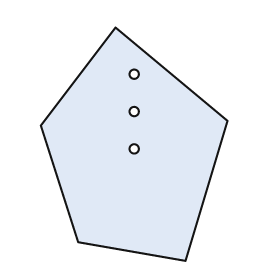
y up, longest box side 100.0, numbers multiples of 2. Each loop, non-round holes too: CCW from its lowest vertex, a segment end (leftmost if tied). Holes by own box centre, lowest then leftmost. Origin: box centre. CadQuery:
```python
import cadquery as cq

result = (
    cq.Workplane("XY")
    .moveTo(22.0, -50.0)
    .lineTo(40.0, 10.0)
    .lineTo(-8.0, 50.0)
    .lineTo(-40.0, 8.0)
    .lineTo(-24.0, -42.0)
    .close()
    .moveTo(0.0, -2.0)
    .circle(2.0)
    .moveTo(0.0, 14.0)
    .circle(2.0)
    .moveTo(0.0, 30.0)
    .circle(2.0)
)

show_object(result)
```